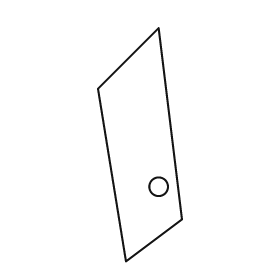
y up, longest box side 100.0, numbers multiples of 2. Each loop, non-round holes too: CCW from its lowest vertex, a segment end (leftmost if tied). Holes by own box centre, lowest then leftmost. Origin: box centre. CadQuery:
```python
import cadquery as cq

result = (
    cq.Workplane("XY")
    .moveTo(-6.0, -50.0)
    .lineTo(18.0, -32.0)
    .lineTo(8.0, 50.0)
    .lineTo(-18.0, 24.0)
    .close()
    .moveTo(8.0, -18.0)
    .circle(4.0)
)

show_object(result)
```